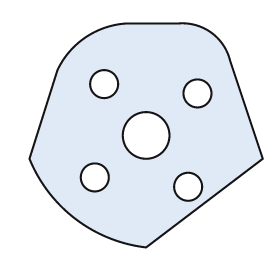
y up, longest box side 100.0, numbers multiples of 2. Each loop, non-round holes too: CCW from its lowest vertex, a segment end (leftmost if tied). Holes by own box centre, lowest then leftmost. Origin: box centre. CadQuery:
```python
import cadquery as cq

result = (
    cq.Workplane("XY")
    .moveTo(0.0, -48.0)
    .lineTo(50.0, -10.0)
    .lineTo(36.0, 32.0)
    .threePointArc((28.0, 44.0), (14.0, 48.0))
    .lineTo(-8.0, 48.0)
    .threePointArc((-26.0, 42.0), (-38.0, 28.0))
    .lineTo(-50.0, -10.0)
    .threePointArc((-30.0, -36.0), (0.0, -48.0))
    .close()
    .moveTo(18.0, -22.0)
    .circle(6.0)
    .moveTo(-22.0, -18.0)
    .circle(6.0)
    .moveTo(0.0, 0.0)
    .circle(10.0)
    .moveTo(22.0, 18.0)
    .circle(6.0)
    .moveTo(-18.0, 22.0)
    .circle(6.0)
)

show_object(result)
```